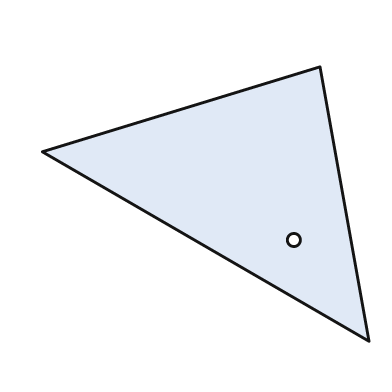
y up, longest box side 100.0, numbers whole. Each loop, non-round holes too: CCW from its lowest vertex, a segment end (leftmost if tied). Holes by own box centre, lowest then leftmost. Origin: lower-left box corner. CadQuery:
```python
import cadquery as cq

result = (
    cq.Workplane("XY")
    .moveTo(100.0, 0.0)
    .lineTo(85.0, 84.0)
    .lineTo(0.0, 58.0)
    .close()
    .moveTo(77.0, 31.0)
    .circle(2.0)
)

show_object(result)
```